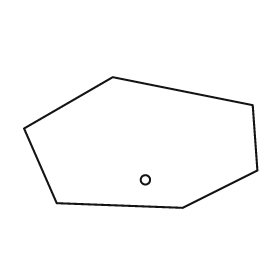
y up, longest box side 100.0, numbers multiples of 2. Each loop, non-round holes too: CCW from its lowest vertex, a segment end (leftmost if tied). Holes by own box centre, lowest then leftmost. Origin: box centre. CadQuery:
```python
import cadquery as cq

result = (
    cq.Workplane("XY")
    .moveTo(18.0, -28.0)
    .lineTo(50.0, -12.0)
    .lineTo(48.0, 16.0)
    .lineTo(-12.0, 28.0)
    .lineTo(-50.0, 6.0)
    .lineTo(-36.0, -26.0)
    .close()
    .moveTo(2.0, -16.0)
    .circle(2.0)
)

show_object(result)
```